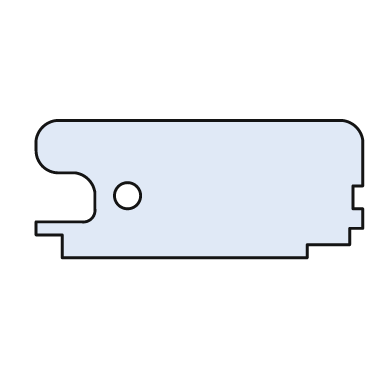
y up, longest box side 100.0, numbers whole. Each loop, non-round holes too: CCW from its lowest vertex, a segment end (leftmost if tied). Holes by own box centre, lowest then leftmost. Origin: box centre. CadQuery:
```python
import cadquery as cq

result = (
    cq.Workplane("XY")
    .moveTo(-42.0, -21.0)
    .lineTo(33.0, -21.0)
    .lineTo(33.0, -17.0)
    .lineTo(46.0, -17.0)
    .lineTo(46.0, -12.0)
    .lineTo(50.0, -12.0)
    .lineTo(50.0, -6.0)
    .lineTo(47.0, -6.0)
    .lineTo(47.0, 1.0)
    .lineTo(50.0, 1.0)
    .lineTo(50.0, 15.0)
    .threePointArc((48.0, 19.0), (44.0, 21.0))
    .lineTo(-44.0, 21.0)
    .threePointArc((-48.0, 19.0), (-50.0, 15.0))
    .lineTo(-50.0, 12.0)
    .threePointArc((-48.0, 7.0), (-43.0, 5.0))
    .lineTo(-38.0, 5.0)
    .threePointArc((-34.0, 3.0), (-32.0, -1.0))
    .lineTo(-32.0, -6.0)
    .threePointArc((-33.0, -9.0), (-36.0, -10.0))
    .lineTo(-50.0, -10.0)
    .lineTo(-50.0, -14.0)
    .lineTo(-42.0, -14.0)
    .close()
    .moveTo(-22.0, -2.0)
    .circle(4.0)
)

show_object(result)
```